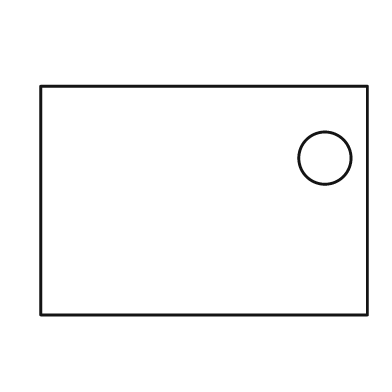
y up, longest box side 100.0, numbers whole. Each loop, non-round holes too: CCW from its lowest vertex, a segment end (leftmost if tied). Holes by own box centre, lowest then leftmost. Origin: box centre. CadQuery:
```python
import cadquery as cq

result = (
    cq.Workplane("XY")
    .moveTo(-50.0, -35.0)
    .lineTo(50.0, -35.0)
    .lineTo(50.0, 35.0)
    .lineTo(-50.0, 35.0)
    .close()
    .moveTo(37.0, 13.0)
    .circle(8.0)
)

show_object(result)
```